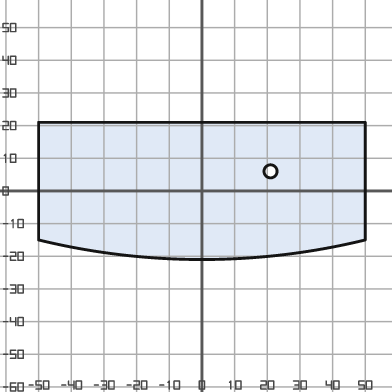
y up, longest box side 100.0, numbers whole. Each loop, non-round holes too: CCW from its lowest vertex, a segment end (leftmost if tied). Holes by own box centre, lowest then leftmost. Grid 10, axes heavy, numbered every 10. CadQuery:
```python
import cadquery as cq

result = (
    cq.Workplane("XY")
    .moveTo(-50.0, -15.0)
    .threePointArc((0.0, -21.0), (50.0, -15.0))
    .lineTo(50.0, 21.0)
    .lineTo(-50.0, 21.0)
    .close()
    .moveTo(21.0, 6.0)
    .circle(2.0)
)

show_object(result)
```